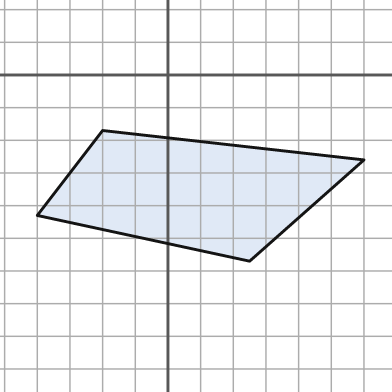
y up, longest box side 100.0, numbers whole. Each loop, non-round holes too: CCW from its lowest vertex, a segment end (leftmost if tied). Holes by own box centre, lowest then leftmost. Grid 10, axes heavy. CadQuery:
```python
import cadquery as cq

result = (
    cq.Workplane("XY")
    .moveTo(25.0, -57.0)
    .lineTo(60.0, -26.0)
    .lineTo(-20.0, -17.0)
    .lineTo(-40.0, -43.0)
    .close()
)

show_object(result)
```